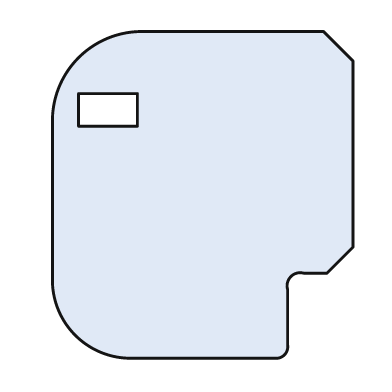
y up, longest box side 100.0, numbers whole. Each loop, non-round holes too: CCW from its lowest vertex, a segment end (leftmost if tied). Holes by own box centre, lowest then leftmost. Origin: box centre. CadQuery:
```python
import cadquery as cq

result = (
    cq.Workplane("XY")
    .moveTo(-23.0, -50.0)
    .lineTo(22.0, -50.0)
    .threePointArc((25.0, -49.0), (26.0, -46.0))
    .lineTo(26.0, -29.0)
    .threePointArc((27.0, -25.0), (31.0, -24.0))
    .lineTo(38.0, -24.0)
    .lineTo(46.0, -16.0)
    .lineTo(46.0, 41.0)
    .lineTo(37.0, 50.0)
    .lineTo(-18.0, 50.0)
    .threePointArc((-38.0, 42.0), (-46.0, 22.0))
    .lineTo(-46.0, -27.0)
    .threePointArc((-39.0, -43.0), (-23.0, -50.0))
    .close()
    .moveTo(-38.0, 21.0)
    .lineTo(-20.0, 21.0)
    .lineTo(-20.0, 31.0)
    .lineTo(-38.0, 31.0)
    .close()
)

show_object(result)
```